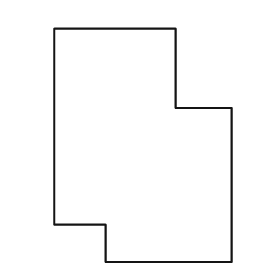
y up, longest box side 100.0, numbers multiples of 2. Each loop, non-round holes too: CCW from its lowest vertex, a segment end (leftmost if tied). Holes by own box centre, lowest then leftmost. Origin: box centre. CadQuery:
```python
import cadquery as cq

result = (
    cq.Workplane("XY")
    .moveTo(-16.0, -50.0)
    .lineTo(38.0, -50.0)
    .lineTo(38.0, 16.0)
    .lineTo(14.0, 16.0)
    .lineTo(14.0, 50.0)
    .lineTo(-38.0, 50.0)
    .lineTo(-38.0, -34.0)
    .lineTo(-16.0, -34.0)
    .close()
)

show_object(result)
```